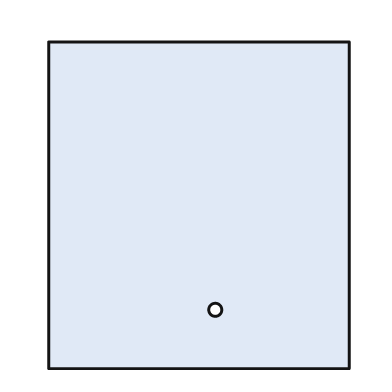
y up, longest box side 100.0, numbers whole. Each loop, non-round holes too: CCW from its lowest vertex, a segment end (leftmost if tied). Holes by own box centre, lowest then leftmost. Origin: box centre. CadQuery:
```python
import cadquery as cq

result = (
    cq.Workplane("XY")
    .moveTo(-46.0, -50.0)
    .lineTo(46.0, -50.0)
    .lineTo(46.0, 50.0)
    .lineTo(-46.0, 50.0)
    .close()
    .moveTo(5.0, -32.0)
    .circle(2.0)
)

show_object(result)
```